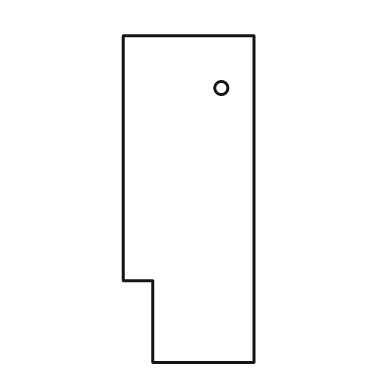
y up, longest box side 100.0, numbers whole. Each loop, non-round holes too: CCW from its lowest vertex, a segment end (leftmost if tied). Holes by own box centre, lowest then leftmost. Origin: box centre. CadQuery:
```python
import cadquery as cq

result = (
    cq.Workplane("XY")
    .moveTo(-11.0, -50.0)
    .lineTo(20.0, -50.0)
    .lineTo(20.0, 50.0)
    .lineTo(-20.0, 50.0)
    .lineTo(-20.0, -25.0)
    .lineTo(-11.0, -25.0)
    .close()
    .moveTo(10.0, 34.0)
    .circle(2.0)
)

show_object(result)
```